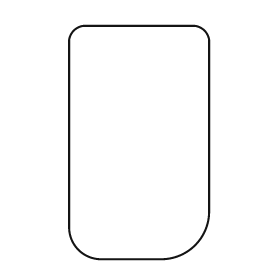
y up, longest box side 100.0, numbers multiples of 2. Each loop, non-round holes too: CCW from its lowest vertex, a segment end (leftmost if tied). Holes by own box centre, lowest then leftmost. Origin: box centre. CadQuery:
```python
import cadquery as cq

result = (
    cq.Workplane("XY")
    .moveTo(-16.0, -50.0)
    .lineTo(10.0, -50.0)
    .threePointArc((24.0, -44.0), (30.0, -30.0))
    .lineTo(30.0, 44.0)
    .threePointArc((28.0, 48.0), (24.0, 50.0))
    .lineTo(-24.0, 50.0)
    .threePointArc((-28.0, 48.0), (-30.0, 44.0))
    .lineTo(-30.0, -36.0)
    .threePointArc((-26.0, -46.0), (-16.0, -50.0))
    .close()
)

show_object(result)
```